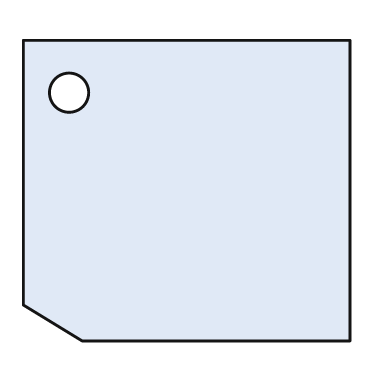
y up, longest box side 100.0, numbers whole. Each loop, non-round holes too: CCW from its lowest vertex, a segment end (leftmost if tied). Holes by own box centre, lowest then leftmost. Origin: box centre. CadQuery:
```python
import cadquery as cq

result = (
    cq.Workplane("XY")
    .moveTo(-32.0, -46.0)
    .lineTo(50.0, -46.0)
    .lineTo(50.0, 46.0)
    .lineTo(-50.0, 46.0)
    .lineTo(-50.0, -35.0)
    .close()
    .moveTo(-36.0, 30.0)
    .circle(6.0)
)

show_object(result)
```